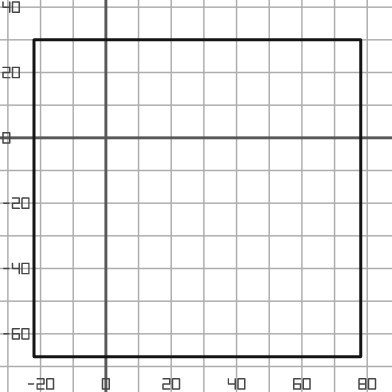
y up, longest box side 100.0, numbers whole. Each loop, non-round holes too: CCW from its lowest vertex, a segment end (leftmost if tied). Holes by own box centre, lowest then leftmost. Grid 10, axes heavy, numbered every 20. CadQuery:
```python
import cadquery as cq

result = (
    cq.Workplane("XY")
    .moveTo(-22.0, -67.0)
    .lineTo(78.0, -67.0)
    .lineTo(78.0, 30.0)
    .lineTo(-22.0, 30.0)
    .close()
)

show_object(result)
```